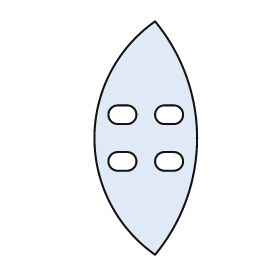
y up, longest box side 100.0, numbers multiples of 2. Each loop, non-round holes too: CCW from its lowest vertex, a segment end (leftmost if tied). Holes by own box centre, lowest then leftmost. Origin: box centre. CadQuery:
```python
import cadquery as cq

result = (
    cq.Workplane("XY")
    .moveTo(4.0, -50.0)
    .threePointArc((22.0, 0.0), (4.0, 50.0))
    .threePointArc((-22.0, 0.0), (4.0, -50.0))
    .close()
    .moveTo(-12.0, -14.0)
    .lineTo(-8.0, -14.0)
    .threePointArc((-4.0, -10.0), (-8.0, -6.0))
    .lineTo(-12.0, -6.0)
    .threePointArc((-16.0, -10.0), (-12.0, -14.0))
    .close()
    .moveTo(8.0, -14.0)
    .lineTo(12.0, -14.0)
    .threePointArc((16.0, -10.0), (12.0, -6.0))
    .lineTo(8.0, -6.0)
    .threePointArc((4.0, -10.0), (8.0, -14.0))
    .close()
    .moveTo(-12.0, 6.0)
    .lineTo(-8.0, 6.0)
    .threePointArc((-4.0, 10.0), (-8.0, 14.0))
    .lineTo(-12.0, 14.0)
    .threePointArc((-16.0, 10.0), (-12.0, 6.0))
    .close()
    .moveTo(8.0, 6.0)
    .lineTo(12.0, 6.0)
    .threePointArc((16.0, 10.0), (12.0, 14.0))
    .lineTo(8.0, 14.0)
    .threePointArc((4.0, 10.0), (8.0, 6.0))
    .close()
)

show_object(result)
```